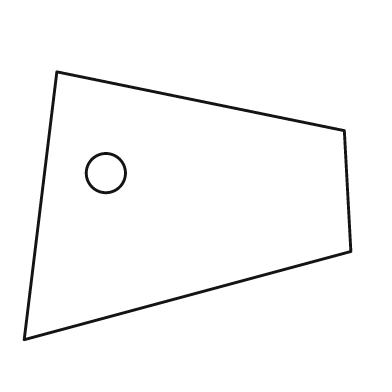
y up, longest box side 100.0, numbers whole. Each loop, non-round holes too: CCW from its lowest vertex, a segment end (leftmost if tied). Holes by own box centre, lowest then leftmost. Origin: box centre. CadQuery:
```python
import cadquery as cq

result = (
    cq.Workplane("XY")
    .moveTo(-50.0, -41.0)
    .lineTo(50.0, -14.0)
    .lineTo(48.0, 23.0)
    .lineTo(-40.0, 41.0)
    .close()
    .moveTo(-25.0, 10.0)
    .circle(6.0)
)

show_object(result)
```